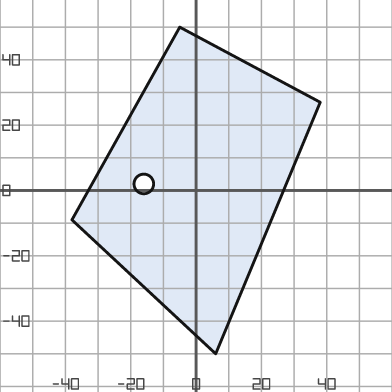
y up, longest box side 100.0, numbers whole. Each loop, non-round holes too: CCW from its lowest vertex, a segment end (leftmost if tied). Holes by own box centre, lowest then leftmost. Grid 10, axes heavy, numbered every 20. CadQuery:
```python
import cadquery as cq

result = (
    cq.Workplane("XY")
    .moveTo(6.0, -50.0)
    .lineTo(38.0, 27.0)
    .lineTo(-5.0, 50.0)
    .lineTo(-38.0, -9.0)
    .close()
    .moveTo(-16.0, 2.0)
    .circle(3.0)
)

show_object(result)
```